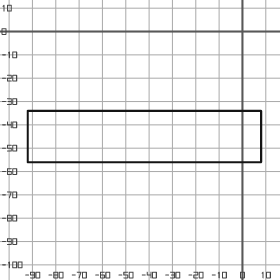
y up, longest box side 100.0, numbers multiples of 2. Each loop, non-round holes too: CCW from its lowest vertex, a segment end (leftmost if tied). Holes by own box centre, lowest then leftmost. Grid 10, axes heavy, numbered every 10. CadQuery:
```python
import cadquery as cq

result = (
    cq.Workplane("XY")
    .moveTo(-92.0, -56.0)
    .lineTo(8.0, -56.0)
    .lineTo(8.0, -34.0)
    .lineTo(-92.0, -34.0)
    .close()
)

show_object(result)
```